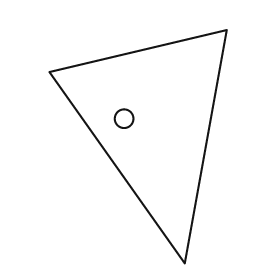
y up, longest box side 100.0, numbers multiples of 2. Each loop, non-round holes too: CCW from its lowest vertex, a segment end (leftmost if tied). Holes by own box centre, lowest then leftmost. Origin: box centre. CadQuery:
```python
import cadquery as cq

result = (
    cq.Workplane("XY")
    .moveTo(20.0, -50.0)
    .lineTo(38.0, 50.0)
    .lineTo(-38.0, 32.0)
    .close()
    .moveTo(-6.0, 12.0)
    .circle(4.0)
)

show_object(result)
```